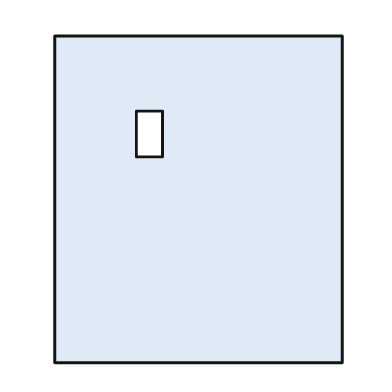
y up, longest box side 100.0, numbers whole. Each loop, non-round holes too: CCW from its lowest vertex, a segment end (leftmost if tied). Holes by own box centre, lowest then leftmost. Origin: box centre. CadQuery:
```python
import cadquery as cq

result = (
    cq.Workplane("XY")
    .moveTo(-44.0, -50.0)
    .lineTo(44.0, -50.0)
    .lineTo(44.0, 50.0)
    .lineTo(-44.0, 50.0)
    .close()
    .moveTo(-19.0, 13.0)
    .lineTo(-11.0, 13.0)
    .lineTo(-11.0, 27.0)
    .lineTo(-19.0, 27.0)
    .close()
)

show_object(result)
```